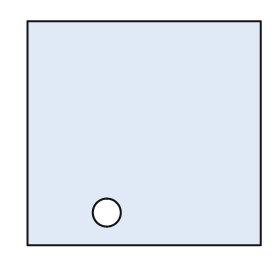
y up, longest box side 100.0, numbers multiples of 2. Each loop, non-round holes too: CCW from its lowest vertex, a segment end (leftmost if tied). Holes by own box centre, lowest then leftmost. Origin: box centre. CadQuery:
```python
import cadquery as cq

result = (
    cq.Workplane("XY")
    .moveTo(-50.0, -48.0)
    .lineTo(50.0, -48.0)
    .lineTo(50.0, 48.0)
    .lineTo(-50.0, 48.0)
    .close()
    .moveTo(-16.0, -34.0)
    .circle(6.0)
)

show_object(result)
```